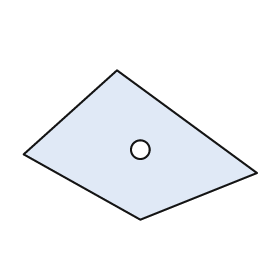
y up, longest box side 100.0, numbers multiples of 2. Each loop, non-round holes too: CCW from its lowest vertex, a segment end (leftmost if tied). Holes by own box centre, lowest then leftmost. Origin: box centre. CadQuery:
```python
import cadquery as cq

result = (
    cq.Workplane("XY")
    .moveTo(0.0, -32.0)
    .lineTo(50.0, -12.0)
    .lineTo(-10.0, 32.0)
    .lineTo(-50.0, -4.0)
    .close()
    .moveTo(0.0, -2.0)
    .circle(4.0)
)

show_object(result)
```